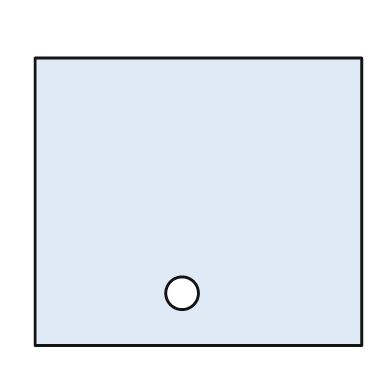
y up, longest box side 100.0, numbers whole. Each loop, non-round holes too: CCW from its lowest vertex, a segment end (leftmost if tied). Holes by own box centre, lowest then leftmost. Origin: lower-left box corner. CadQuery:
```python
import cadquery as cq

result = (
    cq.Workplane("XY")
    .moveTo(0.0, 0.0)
    .lineTo(100.0, 0.0)
    .lineTo(100.0, 88.0)
    .lineTo(0.0, 88.0)
    .close()
    .moveTo(45.0, 16.0)
    .circle(5.0)
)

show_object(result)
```